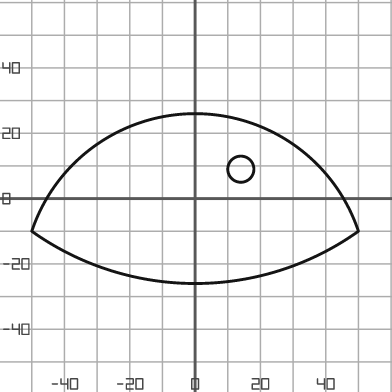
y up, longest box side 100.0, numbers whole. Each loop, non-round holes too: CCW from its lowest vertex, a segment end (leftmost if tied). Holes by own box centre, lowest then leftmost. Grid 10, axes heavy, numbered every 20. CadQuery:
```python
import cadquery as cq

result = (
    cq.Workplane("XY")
    .moveTo(-50.0, -10.0)
    .threePointArc((0.0, -26.0), (50.0, -10.0))
    .threePointArc((0.0, 26.0), (-50.0, -10.0))
    .close()
    .moveTo(14.0, 9.0)
    .circle(4.0)
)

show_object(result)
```